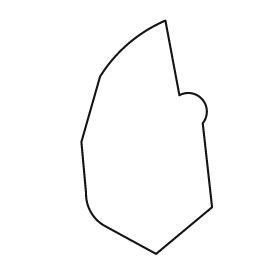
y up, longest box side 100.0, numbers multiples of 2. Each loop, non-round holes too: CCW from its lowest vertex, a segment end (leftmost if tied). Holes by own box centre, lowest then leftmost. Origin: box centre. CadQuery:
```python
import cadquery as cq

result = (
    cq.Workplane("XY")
    .moveTo(4.0, -50.0)
    .lineTo(28.0, -30.0)
    .lineTo(24.0, 6.0)
    .threePointArc((24.0, 16.0), (14.0, 18.0))
    .lineTo(8.0, 50.0)
    .threePointArc((-8.0, 40.0), (-20.0, 26.0))
    .lineTo(-28.0, -2.0)
    .lineTo(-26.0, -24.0)
    .threePointArc((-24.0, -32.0), (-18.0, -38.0))
    .close()
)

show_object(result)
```